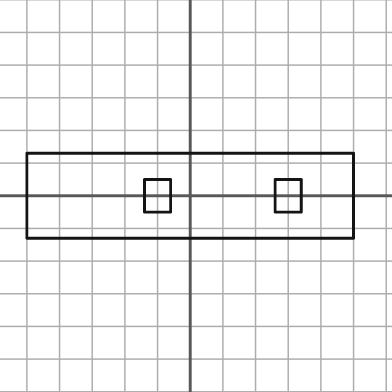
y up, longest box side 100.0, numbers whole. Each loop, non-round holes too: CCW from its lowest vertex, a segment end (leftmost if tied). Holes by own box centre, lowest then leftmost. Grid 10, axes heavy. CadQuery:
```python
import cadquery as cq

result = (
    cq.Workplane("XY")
    .moveTo(-50.0, -13.0)
    .lineTo(50.0, -13.0)
    .lineTo(50.0, 13.0)
    .lineTo(-50.0, 13.0)
    .close()
    .moveTo(-14.0, -5.0)
    .lineTo(-6.0, -5.0)
    .lineTo(-6.0, 5.0)
    .lineTo(-14.0, 5.0)
    .close()
    .moveTo(26.0, -5.0)
    .lineTo(34.0, -5.0)
    .lineTo(34.0, 5.0)
    .lineTo(26.0, 5.0)
    .close()
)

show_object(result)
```